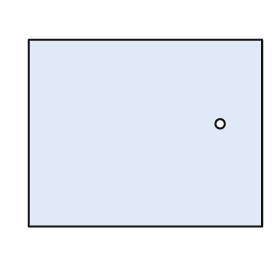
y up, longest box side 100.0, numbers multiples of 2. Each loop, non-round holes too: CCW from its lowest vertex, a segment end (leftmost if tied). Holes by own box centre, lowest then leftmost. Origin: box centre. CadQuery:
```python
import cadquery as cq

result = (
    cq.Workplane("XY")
    .moveTo(-50.0, -40.0)
    .lineTo(50.0, -40.0)
    .lineTo(50.0, 40.0)
    .lineTo(-50.0, 40.0)
    .close()
    .moveTo(32.0, 4.0)
    .circle(2.0)
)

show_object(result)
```